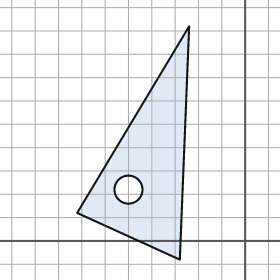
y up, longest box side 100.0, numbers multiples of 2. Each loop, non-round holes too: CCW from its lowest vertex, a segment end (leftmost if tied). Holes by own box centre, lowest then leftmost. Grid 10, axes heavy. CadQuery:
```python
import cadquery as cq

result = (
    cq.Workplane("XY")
    .moveTo(-28.0, -8.0)
    .lineTo(-24.0, 92.0)
    .lineTo(-72.0, 12.0)
    .close()
    .moveTo(-50.0, 22.0)
    .circle(6.0)
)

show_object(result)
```